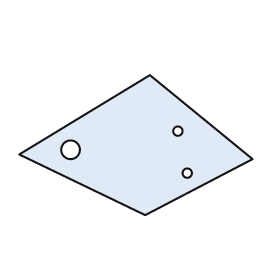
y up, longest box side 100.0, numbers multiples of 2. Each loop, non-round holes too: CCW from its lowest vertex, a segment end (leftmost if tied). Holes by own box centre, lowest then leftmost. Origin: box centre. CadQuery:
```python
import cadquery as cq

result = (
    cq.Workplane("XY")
    .moveTo(4.0, -30.0)
    .lineTo(50.0, -6.0)
    .lineTo(6.0, 30.0)
    .lineTo(-50.0, -4.0)
    .close()
    .moveTo(22.0, -12.0)
    .circle(2.0)
    .moveTo(-28.0, -2.0)
    .circle(4.0)
    .moveTo(18.0, 6.0)
    .circle(2.0)
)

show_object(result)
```